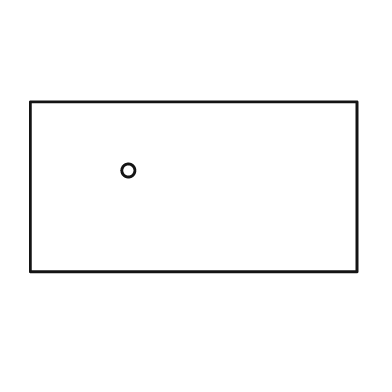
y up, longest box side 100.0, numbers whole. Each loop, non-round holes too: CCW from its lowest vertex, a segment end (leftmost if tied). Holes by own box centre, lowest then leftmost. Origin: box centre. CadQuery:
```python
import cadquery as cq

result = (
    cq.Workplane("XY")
    .moveTo(-50.0, -26.0)
    .lineTo(50.0, -26.0)
    .lineTo(50.0, 26.0)
    .lineTo(-50.0, 26.0)
    .close()
    .moveTo(-20.0, 5.0)
    .circle(2.0)
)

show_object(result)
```